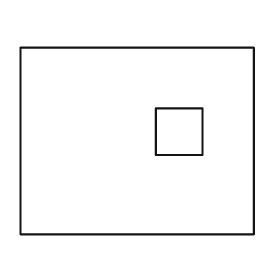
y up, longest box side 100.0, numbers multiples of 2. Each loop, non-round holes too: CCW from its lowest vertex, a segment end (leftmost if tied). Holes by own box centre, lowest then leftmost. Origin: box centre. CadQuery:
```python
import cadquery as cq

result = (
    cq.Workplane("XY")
    .moveTo(-50.0, -40.0)
    .lineTo(50.0, -40.0)
    .lineTo(50.0, 40.0)
    .lineTo(-50.0, 40.0)
    .close()
    .moveTo(8.0, -6.0)
    .lineTo(28.0, -6.0)
    .lineTo(28.0, 14.0)
    .lineTo(8.0, 14.0)
    .close()
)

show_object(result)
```